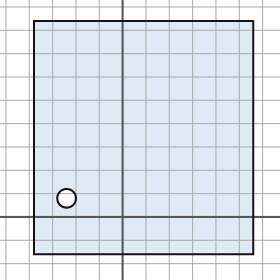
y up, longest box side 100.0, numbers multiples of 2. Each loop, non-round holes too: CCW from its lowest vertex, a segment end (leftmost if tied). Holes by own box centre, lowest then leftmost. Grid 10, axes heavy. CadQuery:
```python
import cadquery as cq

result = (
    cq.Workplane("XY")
    .moveTo(-38.0, -16.0)
    .lineTo(56.0, -16.0)
    .lineTo(56.0, 84.0)
    .lineTo(-38.0, 84.0)
    .close()
    .moveTo(-24.0, 8.0)
    .circle(4.0)
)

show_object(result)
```